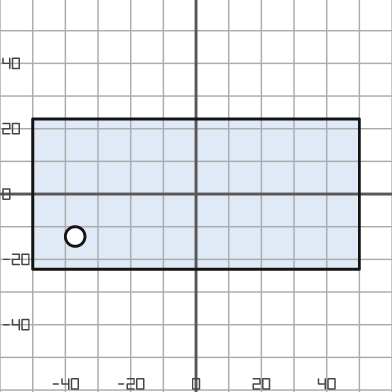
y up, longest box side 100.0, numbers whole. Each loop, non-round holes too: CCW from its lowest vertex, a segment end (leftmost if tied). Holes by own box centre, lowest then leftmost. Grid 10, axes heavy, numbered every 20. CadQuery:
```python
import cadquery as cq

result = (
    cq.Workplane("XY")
    .moveTo(-50.0, -23.0)
    .lineTo(50.0, -23.0)
    .lineTo(50.0, 23.0)
    .lineTo(-50.0, 23.0)
    .close()
    .moveTo(-37.0, -13.0)
    .circle(3.0)
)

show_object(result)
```